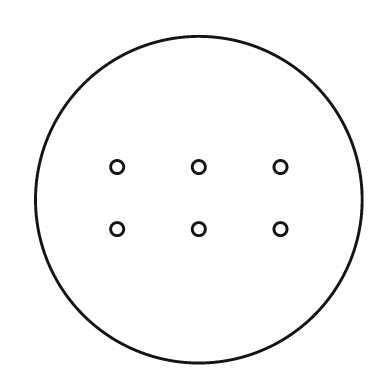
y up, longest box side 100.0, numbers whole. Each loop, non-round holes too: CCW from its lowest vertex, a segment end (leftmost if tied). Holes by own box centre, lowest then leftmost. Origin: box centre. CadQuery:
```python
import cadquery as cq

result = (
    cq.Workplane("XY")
    .moveTo(0.0, 0.0)
    .circle(50.0)
    .moveTo(-25.0, -9.0)
    .circle(2.0)
    .moveTo(0.0, -9.0)
    .circle(2.0)
    .moveTo(25.0, -9.0)
    .circle(2.0)
    .moveTo(-25.0, 10.0)
    .circle(2.0)
    .moveTo(0.0, 10.0)
    .circle(2.0)
    .moveTo(25.0, 10.0)
    .circle(2.0)
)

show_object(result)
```